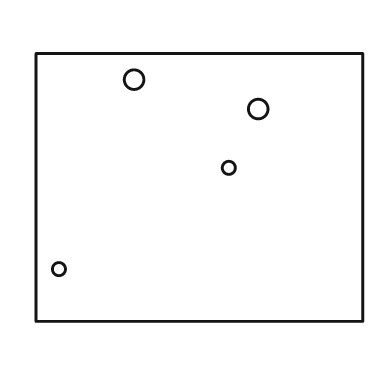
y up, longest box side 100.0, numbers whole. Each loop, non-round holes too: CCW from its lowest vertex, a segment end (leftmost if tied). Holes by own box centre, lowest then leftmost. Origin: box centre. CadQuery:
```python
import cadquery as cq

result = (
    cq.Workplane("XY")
    .moveTo(-50.0, -41.0)
    .lineTo(50.0, -41.0)
    .lineTo(50.0, 41.0)
    .lineTo(-50.0, 41.0)
    .close()
    .moveTo(-43.0, -25.0)
    .circle(2.0)
    .moveTo(9.0, 6.0)
    .circle(2.0)
    .moveTo(18.0, 24.0)
    .circle(3.0)
    .moveTo(-20.0, 33.0)
    .circle(3.0)
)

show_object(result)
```